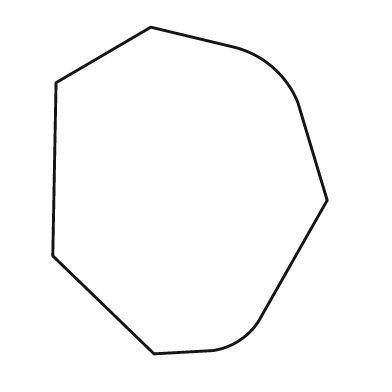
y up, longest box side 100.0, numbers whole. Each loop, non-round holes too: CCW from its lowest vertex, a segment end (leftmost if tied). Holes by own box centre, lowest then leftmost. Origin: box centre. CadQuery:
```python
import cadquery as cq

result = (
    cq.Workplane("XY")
    .moveTo(-11.0, -50.0)
    .lineTo(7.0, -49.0)
    .threePointArc((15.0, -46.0), (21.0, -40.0))
    .lineTo(42.0, -3.0)
    .lineTo(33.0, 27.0)
    .threePointArc((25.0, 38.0), (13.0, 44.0))
    .lineTo(-12.0, 50.0)
    .lineTo(-41.0, 33.0)
    .lineTo(-42.0, -20.0)
    .close()
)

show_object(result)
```